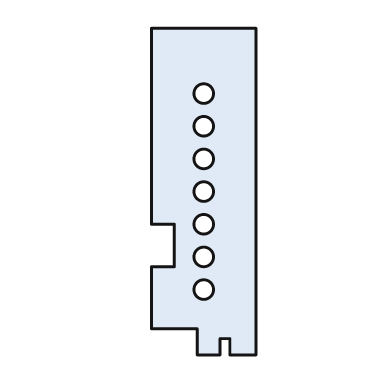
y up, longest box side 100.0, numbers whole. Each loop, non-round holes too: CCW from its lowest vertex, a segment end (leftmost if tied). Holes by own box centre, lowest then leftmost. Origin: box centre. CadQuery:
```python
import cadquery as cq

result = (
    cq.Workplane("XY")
    .moveTo(-2.0, -50.0)
    .lineTo(5.0, -50.0)
    .lineTo(5.0, -45.0)
    .lineTo(8.0, -45.0)
    .lineTo(8.0, -50.0)
    .lineTo(16.0, -50.0)
    .lineTo(16.0, 50.0)
    .lineTo(-16.0, 50.0)
    .lineTo(-16.0, -10.0)
    .lineTo(-9.0, -10.0)
    .lineTo(-9.0, -23.0)
    .lineTo(-16.0, -23.0)
    .lineTo(-16.0, -42.0)
    .lineTo(-2.0, -42.0)
    .close()
    .moveTo(0.0, -30.0)
    .circle(3.0)
    .moveTo(0.0, -20.0)
    .circle(3.0)
    .moveTo(0.0, -10.0)
    .circle(3.0)
    .moveTo(0.0, 0.0)
    .circle(3.0)
    .moveTo(0.0, 10.0)
    .circle(3.0)
    .moveTo(0.0, 20.0)
    .circle(3.0)
    .moveTo(0.0, 30.0)
    .circle(3.0)
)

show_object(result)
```